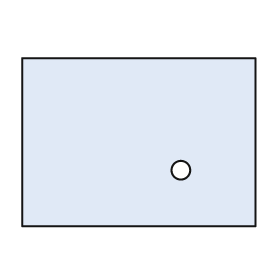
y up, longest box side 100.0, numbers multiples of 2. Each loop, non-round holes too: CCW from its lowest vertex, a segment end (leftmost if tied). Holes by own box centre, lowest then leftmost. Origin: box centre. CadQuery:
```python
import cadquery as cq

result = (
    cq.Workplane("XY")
    .moveTo(-50.0, -36.0)
    .lineTo(50.0, -36.0)
    .lineTo(50.0, 36.0)
    .lineTo(-50.0, 36.0)
    .close()
    .moveTo(18.0, -12.0)
    .circle(4.0)
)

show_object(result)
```